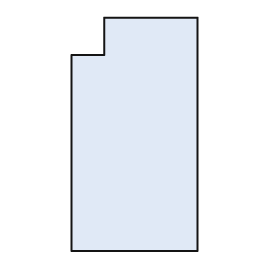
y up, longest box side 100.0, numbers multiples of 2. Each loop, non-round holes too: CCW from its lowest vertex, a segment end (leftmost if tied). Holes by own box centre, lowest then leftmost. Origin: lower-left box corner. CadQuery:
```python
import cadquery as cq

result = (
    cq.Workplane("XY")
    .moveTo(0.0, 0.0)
    .lineTo(54.0, 0.0)
    .lineTo(54.0, 100.0)
    .lineTo(14.0, 100.0)
    .lineTo(14.0, 84.0)
    .lineTo(0.0, 84.0)
    .close()
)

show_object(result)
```